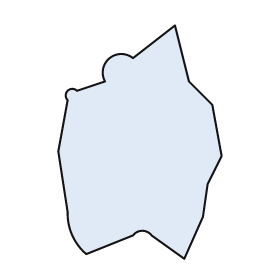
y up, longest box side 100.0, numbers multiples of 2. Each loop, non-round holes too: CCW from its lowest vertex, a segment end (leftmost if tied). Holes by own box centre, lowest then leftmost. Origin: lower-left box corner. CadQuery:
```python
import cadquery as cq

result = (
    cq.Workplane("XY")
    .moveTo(54.0, 0.0)
    .lineTo(62.0, 18.0)
    .lineTo(64.0, 32.0)
    .lineTo(70.0, 44.0)
    .lineTo(66.0, 66.0)
    .lineTo(56.0, 76.0)
    .lineTo(50.0, 100.0)
    .lineTo(32.0, 86.0)
    .threePointArc((22.0, 86.0), (20.0, 76.0))
    .lineTo(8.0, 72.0)
    .threePointArc((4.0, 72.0), (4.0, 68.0))
    .lineTo(0.0, 46.0)
    .lineTo(4.0, 20.0)
    .threePointArc((6.0, 10.0), (12.0, 2.0))
    .lineTo(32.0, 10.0)
    .threePointArc((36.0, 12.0), (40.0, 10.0))
    .close()
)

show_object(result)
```